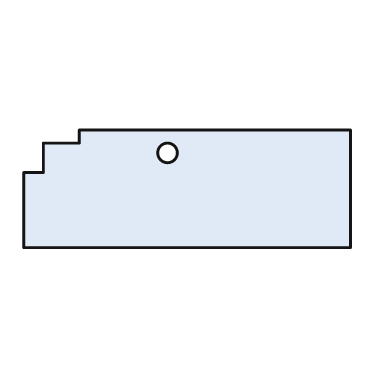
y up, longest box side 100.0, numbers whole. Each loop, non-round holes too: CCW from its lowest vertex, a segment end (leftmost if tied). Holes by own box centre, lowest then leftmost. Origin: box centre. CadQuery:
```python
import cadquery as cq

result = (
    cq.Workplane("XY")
    .moveTo(-50.0, -18.0)
    .lineTo(50.0, -18.0)
    .lineTo(50.0, 18.0)
    .lineTo(-33.0, 18.0)
    .lineTo(-33.0, 14.0)
    .lineTo(-44.0, 14.0)
    .lineTo(-44.0, 5.0)
    .lineTo(-50.0, 5.0)
    .close()
    .moveTo(-6.0, 11.0)
    .circle(3.0)
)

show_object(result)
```